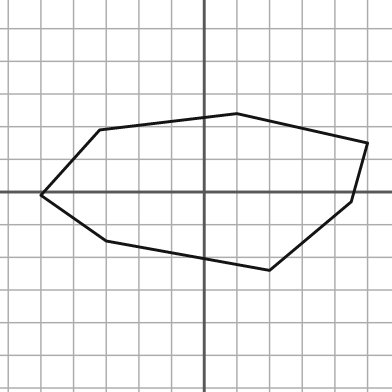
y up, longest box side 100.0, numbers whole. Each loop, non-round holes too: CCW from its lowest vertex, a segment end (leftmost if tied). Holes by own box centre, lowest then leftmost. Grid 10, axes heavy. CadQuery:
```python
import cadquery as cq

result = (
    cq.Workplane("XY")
    .moveTo(20.0, -24.0)
    .lineTo(45.0, -3.0)
    .lineTo(50.0, 15.0)
    .lineTo(10.0, 24.0)
    .lineTo(-32.0, 19.0)
    .lineTo(-50.0, -1.0)
    .lineTo(-30.0, -15.0)
    .close()
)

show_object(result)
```